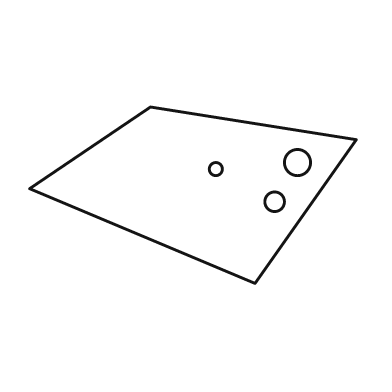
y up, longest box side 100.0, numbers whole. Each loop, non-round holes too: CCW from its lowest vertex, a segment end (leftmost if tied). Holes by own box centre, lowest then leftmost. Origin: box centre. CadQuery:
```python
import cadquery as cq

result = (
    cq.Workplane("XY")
    .moveTo(19.0, -27.0)
    .lineTo(50.0, 17.0)
    .lineTo(-13.0, 27.0)
    .lineTo(-50.0, 2.0)
    .close()
    .moveTo(25.0, -2.0)
    .circle(3.0)
    .moveTo(7.0, 8.0)
    .circle(2.0)
    .moveTo(32.0, 10.0)
    .circle(4.0)
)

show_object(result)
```